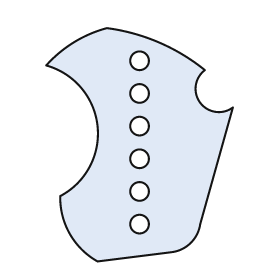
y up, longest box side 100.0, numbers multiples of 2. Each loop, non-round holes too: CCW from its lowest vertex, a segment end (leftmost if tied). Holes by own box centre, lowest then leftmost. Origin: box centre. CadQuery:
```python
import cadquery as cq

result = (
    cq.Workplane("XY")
    .moveTo(-18.0, -50.0)
    .lineTo(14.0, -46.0)
    .threePointArc((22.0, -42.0), (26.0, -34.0))
    .lineTo(40.0, 16.0)
    .threePointArc((26.0, 18.0), (28.0, 32.0))
    .threePointArc((8.0, 44.0), (-14.0, 50.0))
    .threePointArc((-28.0, 44.0), (-40.0, 34.0))
    .threePointArc((-18.0, 8.0), (-34.0, -22.0))
    .threePointArc((-30.0, -38.0), (-18.0, -50.0))
    .close()
    .moveTo(0.0, -34.0)
    .circle(4.0)
    .moveTo(0.0, -20.0)
    .circle(4.0)
    .moveTo(0.0, -6.0)
    .circle(4.0)
    .moveTo(0.0, 8.0)
    .circle(4.0)
    .moveTo(0.0, 22.0)
    .circle(4.0)
    .moveTo(0.0, 36.0)
    .circle(4.0)
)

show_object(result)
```